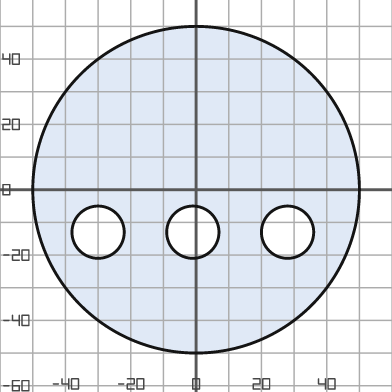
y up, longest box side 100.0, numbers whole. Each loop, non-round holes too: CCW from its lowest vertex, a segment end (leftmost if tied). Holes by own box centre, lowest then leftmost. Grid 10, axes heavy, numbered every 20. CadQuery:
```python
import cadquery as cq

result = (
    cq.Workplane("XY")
    .moveTo(0.0, 0.0)
    .circle(50.0)
    .moveTo(-30.0, -13.0)
    .circle(8.0)
    .moveTo(-1.0, -13.0)
    .circle(8.0)
    .moveTo(28.0, -13.0)
    .circle(8.0)
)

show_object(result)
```